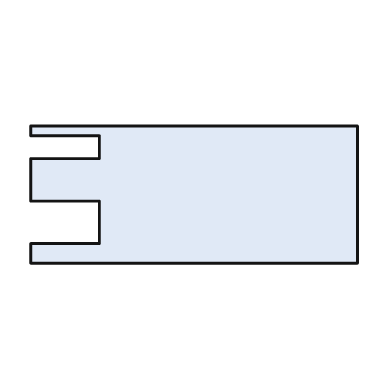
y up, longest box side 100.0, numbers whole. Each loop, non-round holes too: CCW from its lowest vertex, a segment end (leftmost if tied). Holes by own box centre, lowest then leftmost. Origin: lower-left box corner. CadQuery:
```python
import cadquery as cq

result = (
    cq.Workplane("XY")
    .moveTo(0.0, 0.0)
    .lineTo(100.0, 0.0)
    .lineTo(100.0, 42.0)
    .lineTo(0.0, 42.0)
    .lineTo(0.0, 39.0)
    .lineTo(21.0, 39.0)
    .lineTo(21.0, 32.0)
    .lineTo(0.0, 32.0)
    .lineTo(0.0, 19.0)
    .lineTo(21.0, 19.0)
    .lineTo(21.0, 6.0)
    .lineTo(0.0, 6.0)
    .close()
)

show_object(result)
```